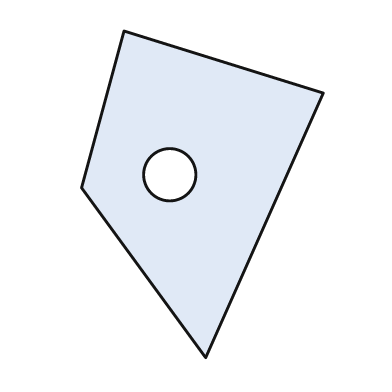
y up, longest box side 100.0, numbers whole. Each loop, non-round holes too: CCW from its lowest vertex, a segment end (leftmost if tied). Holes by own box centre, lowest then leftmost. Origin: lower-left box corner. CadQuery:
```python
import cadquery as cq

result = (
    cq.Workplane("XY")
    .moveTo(38.0, 0.0)
    .lineTo(74.0, 81.0)
    .lineTo(13.0, 100.0)
    .lineTo(0.0, 52.0)
    .close()
    .moveTo(27.0, 56.0)
    .circle(8.0)
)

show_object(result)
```